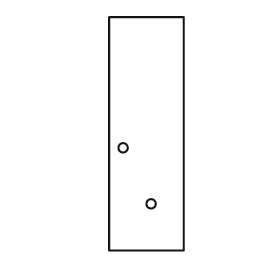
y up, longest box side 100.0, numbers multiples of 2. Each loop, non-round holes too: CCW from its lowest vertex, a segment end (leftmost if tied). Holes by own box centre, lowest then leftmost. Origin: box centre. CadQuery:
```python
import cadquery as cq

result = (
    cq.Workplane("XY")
    .moveTo(-16.0, -50.0)
    .lineTo(16.0, -50.0)
    .lineTo(16.0, 50.0)
    .lineTo(-16.0, 50.0)
    .close()
    .moveTo(2.0, -30.0)
    .circle(2.0)
    .moveTo(-10.0, -6.0)
    .circle(2.0)
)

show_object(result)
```